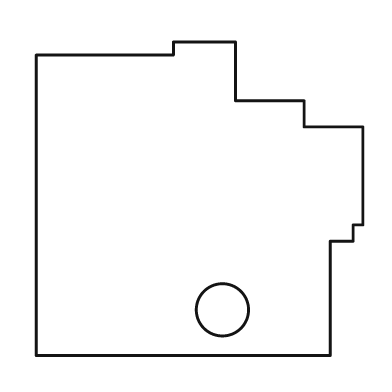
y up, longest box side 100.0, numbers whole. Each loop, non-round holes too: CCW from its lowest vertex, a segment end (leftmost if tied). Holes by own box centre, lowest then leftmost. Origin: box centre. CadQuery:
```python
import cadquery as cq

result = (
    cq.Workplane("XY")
    .moveTo(-50.0, -48.0)
    .lineTo(40.0, -48.0)
    .lineTo(40.0, -13.0)
    .lineTo(47.0, -13.0)
    .lineTo(47.0, -8.0)
    .lineTo(50.0, -8.0)
    .lineTo(50.0, 22.0)
    .lineTo(32.0, 22.0)
    .lineTo(32.0, 30.0)
    .lineTo(11.0, 30.0)
    .lineTo(11.0, 48.0)
    .lineTo(-8.0, 48.0)
    .lineTo(-8.0, 44.0)
    .lineTo(-50.0, 44.0)
    .close()
    .moveTo(7.0, -34.0)
    .circle(8.0)
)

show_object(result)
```